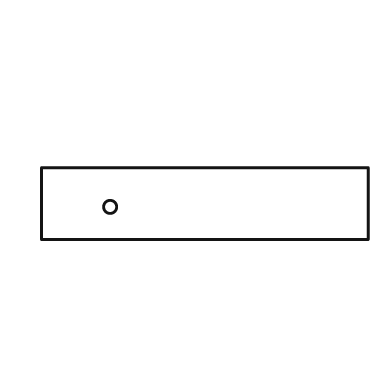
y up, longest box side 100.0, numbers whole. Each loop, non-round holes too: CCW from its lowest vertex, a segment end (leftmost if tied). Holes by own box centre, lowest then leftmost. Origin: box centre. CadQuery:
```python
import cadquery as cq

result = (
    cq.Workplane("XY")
    .moveTo(-50.0, -11.0)
    .lineTo(50.0, -11.0)
    .lineTo(50.0, 11.0)
    .lineTo(-50.0, 11.0)
    .close()
    .moveTo(-29.0, -1.0)
    .circle(2.0)
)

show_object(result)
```